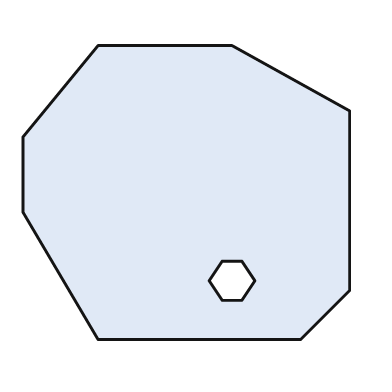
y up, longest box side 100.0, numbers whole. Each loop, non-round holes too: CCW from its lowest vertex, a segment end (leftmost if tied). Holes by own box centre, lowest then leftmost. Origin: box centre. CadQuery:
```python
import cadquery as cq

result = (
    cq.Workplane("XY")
    .moveTo(-27.0, -45.0)
    .lineTo(35.0, -45.0)
    .lineTo(50.0, -30.0)
    .lineTo(50.0, 25.0)
    .lineTo(14.0, 45.0)
    .lineTo(-27.0, 45.0)
    .lineTo(-50.0, 17.0)
    .lineTo(-50.0, -6.0)
    .close()
    .moveTo(11.0, -33.0)
    .lineTo(17.0, -33.0)
    .lineTo(21.0, -27.0)
    .lineTo(17.0, -21.0)
    .lineTo(11.0, -21.0)
    .lineTo(7.0, -27.0)
    .close()
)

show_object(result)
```